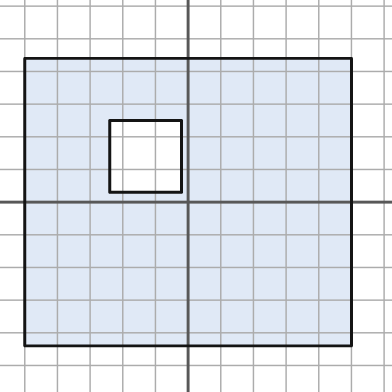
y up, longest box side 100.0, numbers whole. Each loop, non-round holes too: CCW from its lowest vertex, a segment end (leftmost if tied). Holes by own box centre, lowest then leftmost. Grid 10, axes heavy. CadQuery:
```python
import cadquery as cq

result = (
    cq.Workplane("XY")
    .moveTo(-50.0, -44.0)
    .lineTo(50.0, -44.0)
    .lineTo(50.0, 44.0)
    .lineTo(-50.0, 44.0)
    .close()
    .moveTo(-24.0, 3.0)
    .lineTo(-2.0, 3.0)
    .lineTo(-2.0, 25.0)
    .lineTo(-24.0, 25.0)
    .close()
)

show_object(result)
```